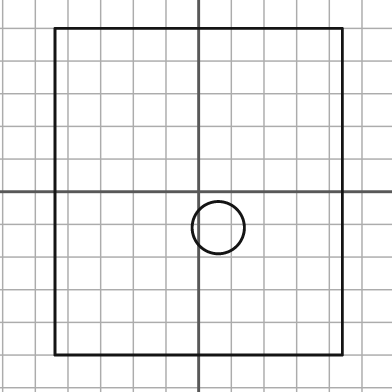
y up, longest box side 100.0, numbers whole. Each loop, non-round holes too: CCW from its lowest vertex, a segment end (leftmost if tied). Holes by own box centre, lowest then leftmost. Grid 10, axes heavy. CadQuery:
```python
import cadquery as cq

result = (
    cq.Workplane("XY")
    .moveTo(-44.0, -50.0)
    .lineTo(44.0, -50.0)
    .lineTo(44.0, 50.0)
    .lineTo(-44.0, 50.0)
    .close()
    .moveTo(6.0, -11.0)
    .circle(8.0)
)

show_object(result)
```